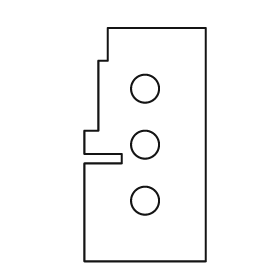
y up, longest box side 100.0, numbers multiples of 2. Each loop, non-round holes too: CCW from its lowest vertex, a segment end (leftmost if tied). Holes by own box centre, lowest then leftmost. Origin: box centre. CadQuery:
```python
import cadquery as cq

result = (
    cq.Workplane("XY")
    .moveTo(-26.0, -50.0)
    .lineTo(26.0, -50.0)
    .lineTo(26.0, 50.0)
    .lineTo(-16.0, 50.0)
    .lineTo(-16.0, 36.0)
    .lineTo(-20.0, 36.0)
    .lineTo(-20.0, 6.0)
    .lineTo(-26.0, 6.0)
    .lineTo(-26.0, -4.0)
    .lineTo(-10.0, -4.0)
    .lineTo(-10.0, -8.0)
    .lineTo(-26.0, -8.0)
    .close()
    .moveTo(0.0, -24.0)
    .circle(6.0)
    .moveTo(0.0, 0.0)
    .circle(6.0)
    .moveTo(0.0, 24.0)
    .circle(6.0)
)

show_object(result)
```